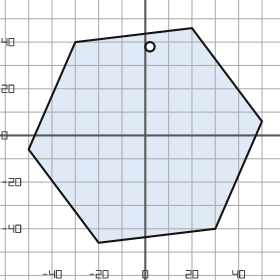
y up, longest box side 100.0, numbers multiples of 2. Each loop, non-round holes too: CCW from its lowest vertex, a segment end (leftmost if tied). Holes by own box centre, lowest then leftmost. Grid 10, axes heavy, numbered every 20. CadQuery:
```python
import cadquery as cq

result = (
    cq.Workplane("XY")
    .moveTo(-20.0, -46.0)
    .lineTo(30.0, -40.0)
    .lineTo(50.0, 6.0)
    .lineTo(20.0, 46.0)
    .lineTo(-30.0, 40.0)
    .lineTo(-50.0, -6.0)
    .close()
    .moveTo(2.0, 38.0)
    .circle(2.0)
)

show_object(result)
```